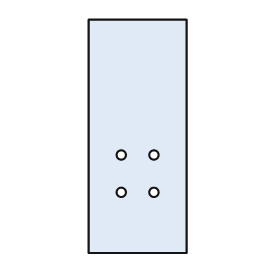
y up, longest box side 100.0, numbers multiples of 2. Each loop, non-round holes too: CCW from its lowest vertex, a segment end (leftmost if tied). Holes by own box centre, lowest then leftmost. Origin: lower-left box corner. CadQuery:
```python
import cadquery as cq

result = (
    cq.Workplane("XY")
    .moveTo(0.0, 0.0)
    .lineTo(42.0, 0.0)
    .lineTo(42.0, 100.0)
    .lineTo(0.0, 100.0)
    .close()
    .moveTo(14.0, 26.0)
    .circle(2.0)
    .moveTo(28.0, 26.0)
    .circle(2.0)
    .moveTo(14.0, 42.0)
    .circle(2.0)
    .moveTo(28.0, 42.0)
    .circle(2.0)
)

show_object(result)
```